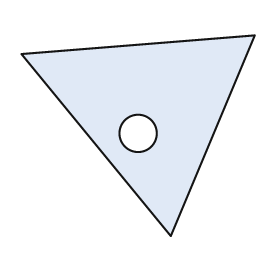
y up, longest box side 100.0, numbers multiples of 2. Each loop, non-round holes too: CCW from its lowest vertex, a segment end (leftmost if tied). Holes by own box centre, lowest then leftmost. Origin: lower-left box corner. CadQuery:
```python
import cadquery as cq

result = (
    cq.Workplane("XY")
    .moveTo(64.0, 0.0)
    .lineTo(100.0, 86.0)
    .lineTo(0.0, 78.0)
    .close()
    .moveTo(50.0, 44.0)
    .circle(8.0)
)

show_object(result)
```